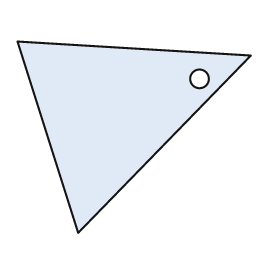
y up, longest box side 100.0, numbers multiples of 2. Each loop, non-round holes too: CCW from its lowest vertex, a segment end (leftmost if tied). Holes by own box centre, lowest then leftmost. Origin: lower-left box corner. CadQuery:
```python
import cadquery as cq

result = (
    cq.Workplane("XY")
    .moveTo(26.0, 0.0)
    .lineTo(100.0, 76.0)
    .lineTo(0.0, 82.0)
    .close()
    .moveTo(78.0, 66.0)
    .circle(4.0)
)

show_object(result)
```